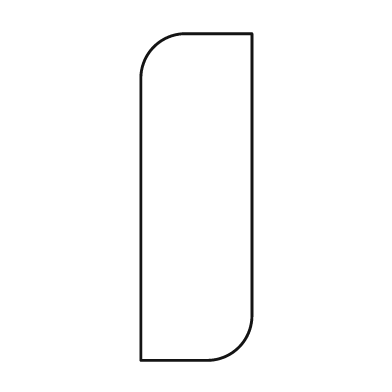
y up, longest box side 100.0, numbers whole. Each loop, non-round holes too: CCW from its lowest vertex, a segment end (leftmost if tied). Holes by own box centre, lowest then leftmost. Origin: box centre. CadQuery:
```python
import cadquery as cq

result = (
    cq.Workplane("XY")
    .moveTo(-17.0, -50.0)
    .lineTo(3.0, -50.0)
    .threePointArc((13.0, -46.0), (17.0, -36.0))
    .lineTo(17.0, 50.0)
    .lineTo(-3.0, 50.0)
    .threePointArc((-13.0, 46.0), (-17.0, 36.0))
    .close()
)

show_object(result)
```